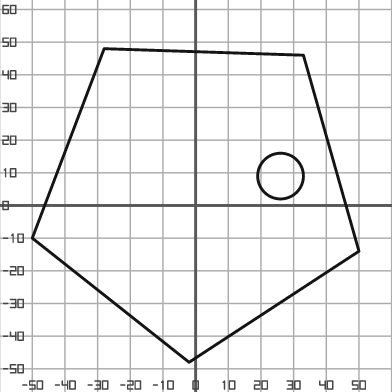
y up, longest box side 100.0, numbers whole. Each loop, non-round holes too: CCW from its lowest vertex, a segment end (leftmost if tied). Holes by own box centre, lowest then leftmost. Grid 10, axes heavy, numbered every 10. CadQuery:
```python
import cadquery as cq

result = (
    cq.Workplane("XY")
    .moveTo(-2.0, -48.0)
    .lineTo(50.0, -14.0)
    .lineTo(33.0, 46.0)
    .lineTo(-28.0, 48.0)
    .lineTo(-50.0, -10.0)
    .close()
    .moveTo(26.0, 9.0)
    .circle(7.0)
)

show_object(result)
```